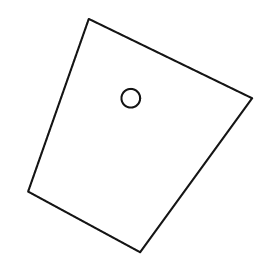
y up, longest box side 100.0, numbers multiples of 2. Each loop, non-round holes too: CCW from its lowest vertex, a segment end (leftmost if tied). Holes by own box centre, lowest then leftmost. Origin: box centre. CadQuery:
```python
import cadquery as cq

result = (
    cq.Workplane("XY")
    .moveTo(0.0, -50.0)
    .lineTo(48.0, 16.0)
    .lineTo(-22.0, 50.0)
    .lineTo(-48.0, -24.0)
    .close()
    .moveTo(-4.0, 16.0)
    .circle(4.0)
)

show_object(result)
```